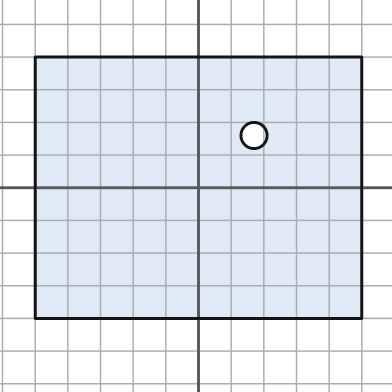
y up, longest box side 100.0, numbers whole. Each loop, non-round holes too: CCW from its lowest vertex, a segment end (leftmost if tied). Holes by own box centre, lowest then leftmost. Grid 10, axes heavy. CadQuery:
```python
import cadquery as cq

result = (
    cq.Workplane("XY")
    .moveTo(-50.0, -40.0)
    .lineTo(50.0, -40.0)
    .lineTo(50.0, 40.0)
    .lineTo(-50.0, 40.0)
    .close()
    .moveTo(17.0, 16.0)
    .circle(4.0)
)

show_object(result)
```